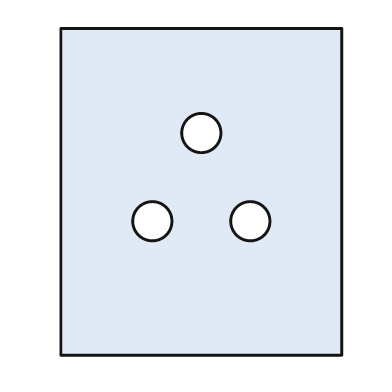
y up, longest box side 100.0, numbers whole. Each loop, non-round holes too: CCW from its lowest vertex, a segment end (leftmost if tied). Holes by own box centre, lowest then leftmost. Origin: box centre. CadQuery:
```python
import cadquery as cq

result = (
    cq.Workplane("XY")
    .moveTo(-43.0, -50.0)
    .lineTo(43.0, -50.0)
    .lineTo(43.0, 50.0)
    .lineTo(-43.0, 50.0)
    .close()
    .moveTo(-15.0, -9.0)
    .circle(6.0)
    .moveTo(15.0, -9.0)
    .circle(6.0)
    .moveTo(0.0, 18.0)
    .circle(6.0)
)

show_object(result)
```